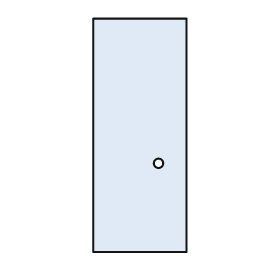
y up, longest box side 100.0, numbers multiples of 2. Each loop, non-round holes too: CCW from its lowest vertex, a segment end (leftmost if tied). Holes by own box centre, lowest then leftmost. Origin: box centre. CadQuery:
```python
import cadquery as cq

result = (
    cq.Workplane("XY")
    .moveTo(-20.0, -50.0)
    .lineTo(20.0, -50.0)
    .lineTo(20.0, 50.0)
    .lineTo(-20.0, 50.0)
    .close()
    .moveTo(8.0, -12.0)
    .circle(2.0)
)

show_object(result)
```